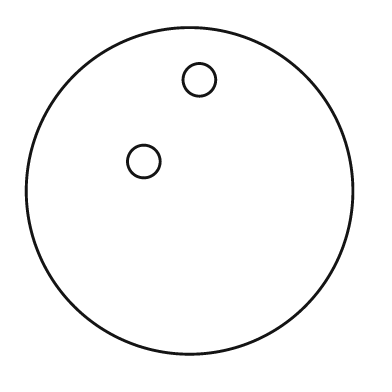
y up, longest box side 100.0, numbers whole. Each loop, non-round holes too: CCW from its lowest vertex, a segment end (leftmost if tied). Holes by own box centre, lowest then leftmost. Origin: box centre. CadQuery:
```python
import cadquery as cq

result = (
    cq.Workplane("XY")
    .moveTo(0.0, 0.0)
    .circle(50.0)
    .moveTo(-14.0, 9.0)
    .circle(5.0)
    .moveTo(3.0, 34.0)
    .circle(5.0)
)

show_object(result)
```